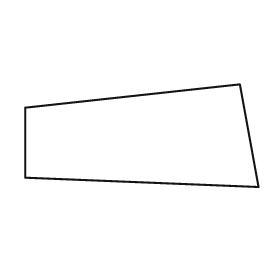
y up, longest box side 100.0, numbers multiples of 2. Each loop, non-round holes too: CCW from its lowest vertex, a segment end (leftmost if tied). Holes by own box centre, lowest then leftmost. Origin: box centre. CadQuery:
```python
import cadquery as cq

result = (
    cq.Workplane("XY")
    .moveTo(50.0, -22.0)
    .lineTo(42.0, 22.0)
    .lineTo(-50.0, 12.0)
    .lineTo(-50.0, -18.0)
    .close()
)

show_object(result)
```